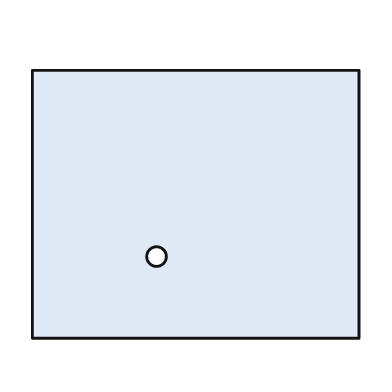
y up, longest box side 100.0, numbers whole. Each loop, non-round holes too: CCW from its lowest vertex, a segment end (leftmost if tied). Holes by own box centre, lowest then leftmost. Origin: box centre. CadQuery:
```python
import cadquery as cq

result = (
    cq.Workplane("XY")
    .moveTo(-50.0, -41.0)
    .lineTo(50.0, -41.0)
    .lineTo(50.0, 41.0)
    .lineTo(-50.0, 41.0)
    .close()
    .moveTo(-12.0, -16.0)
    .circle(3.0)
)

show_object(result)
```